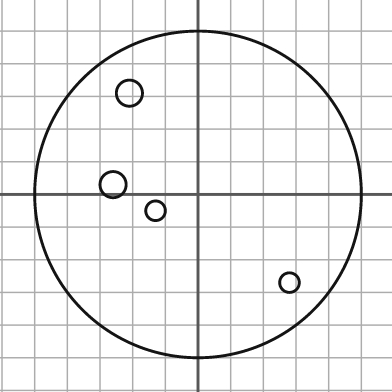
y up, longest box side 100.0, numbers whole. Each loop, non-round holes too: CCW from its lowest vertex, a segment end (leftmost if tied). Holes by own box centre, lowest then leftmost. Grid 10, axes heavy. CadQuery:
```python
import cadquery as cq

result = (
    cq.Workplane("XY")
    .moveTo(0.0, 0.0)
    .circle(50.0)
    .moveTo(28.0, -27.0)
    .circle(3.0)
    .moveTo(-13.0, -5.0)
    .circle(3.0)
    .moveTo(-26.0, 3.0)
    .circle(4.0)
    .moveTo(-21.0, 31.0)
    .circle(4.0)
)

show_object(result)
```